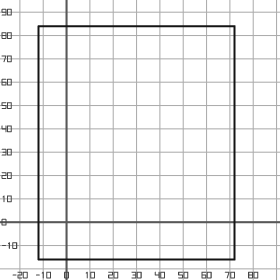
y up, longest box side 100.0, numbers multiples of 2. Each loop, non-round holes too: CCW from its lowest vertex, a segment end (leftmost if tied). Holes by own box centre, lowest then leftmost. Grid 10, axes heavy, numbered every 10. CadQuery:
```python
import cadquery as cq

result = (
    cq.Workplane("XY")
    .moveTo(-12.0, -16.0)
    .lineTo(72.0, -16.0)
    .lineTo(72.0, 84.0)
    .lineTo(-12.0, 84.0)
    .close()
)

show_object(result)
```